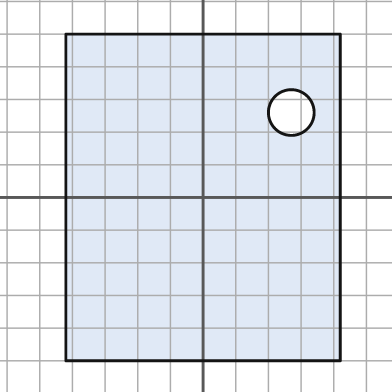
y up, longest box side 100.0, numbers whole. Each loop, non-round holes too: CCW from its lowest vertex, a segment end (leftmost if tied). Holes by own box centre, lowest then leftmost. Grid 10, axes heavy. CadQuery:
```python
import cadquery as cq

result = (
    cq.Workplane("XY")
    .moveTo(-42.0, -50.0)
    .lineTo(42.0, -50.0)
    .lineTo(42.0, 50.0)
    .lineTo(-42.0, 50.0)
    .close()
    .moveTo(27.0, 26.0)
    .circle(7.0)
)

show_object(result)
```